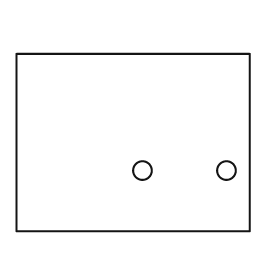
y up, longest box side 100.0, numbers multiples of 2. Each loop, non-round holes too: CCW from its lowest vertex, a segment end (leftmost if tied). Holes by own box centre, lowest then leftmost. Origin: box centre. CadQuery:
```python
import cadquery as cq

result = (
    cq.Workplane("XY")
    .moveTo(-50.0, -38.0)
    .lineTo(50.0, -38.0)
    .lineTo(50.0, 38.0)
    .lineTo(-50.0, 38.0)
    .close()
    .moveTo(4.0, -12.0)
    .circle(4.0)
    .moveTo(40.0, -12.0)
    .circle(4.0)
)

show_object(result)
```